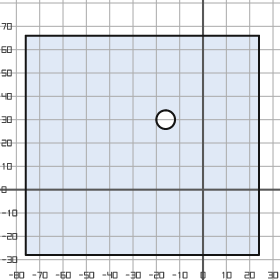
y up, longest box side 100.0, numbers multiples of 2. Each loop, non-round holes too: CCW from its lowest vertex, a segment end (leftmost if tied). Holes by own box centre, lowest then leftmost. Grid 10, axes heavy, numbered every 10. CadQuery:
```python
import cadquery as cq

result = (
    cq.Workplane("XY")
    .moveTo(-76.0, -28.0)
    .lineTo(24.0, -28.0)
    .lineTo(24.0, 66.0)
    .lineTo(-76.0, 66.0)
    .close()
    .moveTo(-16.0, 30.0)
    .circle(4.0)
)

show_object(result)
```